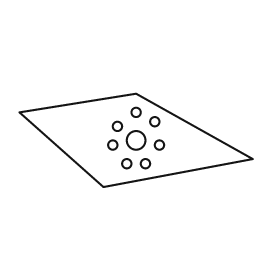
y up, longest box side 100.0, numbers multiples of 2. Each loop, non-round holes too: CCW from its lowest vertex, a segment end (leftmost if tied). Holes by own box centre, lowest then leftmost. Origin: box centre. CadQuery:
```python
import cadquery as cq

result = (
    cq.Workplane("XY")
    .moveTo(-14.0, -20.0)
    .lineTo(50.0, -8.0)
    .lineTo(0.0, 20.0)
    .lineTo(-50.0, 12.0)
    .close()
    .moveTo(-4.0, -10.0)
    .circle(2.0)
    .moveTo(4.0, -10.0)
    .circle(2.0)
    .moveTo(-10.0, -2.0)
    .circle(2.0)
    .moveTo(10.0, -2.0)
    .circle(2.0)
    .moveTo(0.0, 0.0)
    .circle(4.0)
    .moveTo(-8.0, 6.0)
    .circle(2.0)
    .moveTo(8.0, 8.0)
    .circle(2.0)
    .moveTo(0.0, 12.0)
    .circle(2.0)
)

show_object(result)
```